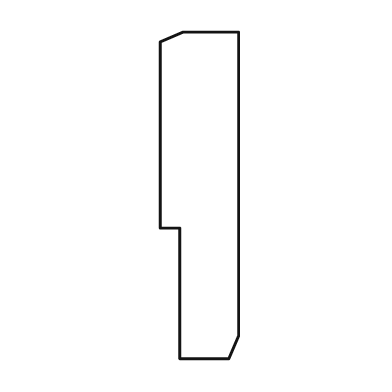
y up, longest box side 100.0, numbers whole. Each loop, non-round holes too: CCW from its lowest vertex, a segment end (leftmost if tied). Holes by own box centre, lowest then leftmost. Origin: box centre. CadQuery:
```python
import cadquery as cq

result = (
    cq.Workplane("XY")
    .moveTo(-6.0, -50.0)
    .lineTo(9.0, -50.0)
    .lineTo(12.0, -43.0)
    .lineTo(12.0, 50.0)
    .lineTo(-5.0, 50.0)
    .lineTo(-12.0, 47.0)
    .lineTo(-12.0, -10.0)
    .lineTo(-6.0, -10.0)
    .close()
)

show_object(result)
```